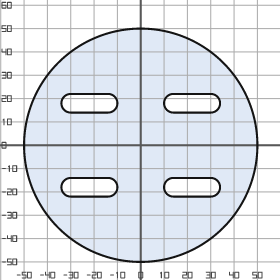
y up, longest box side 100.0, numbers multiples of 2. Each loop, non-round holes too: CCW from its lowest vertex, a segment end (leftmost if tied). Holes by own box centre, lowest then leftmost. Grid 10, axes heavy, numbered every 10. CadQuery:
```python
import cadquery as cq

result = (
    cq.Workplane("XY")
    .moveTo(0.0, 0.0)
    .circle(50.0)
    .moveTo(-30.0, -22.0)
    .lineTo(-14.0, -22.0)
    .threePointArc((-10.0, -18.0), (-14.0, -14.0))
    .lineTo(-30.0, -14.0)
    .threePointArc((-34.0, -18.0), (-30.0, -22.0))
    .close()
    .moveTo(14.0, -22.0)
    .lineTo(30.0, -22.0)
    .threePointArc((34.0, -18.0), (30.0, -14.0))
    .lineTo(14.0, -14.0)
    .threePointArc((10.0, -18.0), (14.0, -22.0))
    .close()
    .moveTo(-30.0, 14.0)
    .lineTo(-14.0, 14.0)
    .threePointArc((-10.0, 18.0), (-14.0, 22.0))
    .lineTo(-30.0, 22.0)
    .threePointArc((-34.0, 18.0), (-30.0, 14.0))
    .close()
    .moveTo(14.0, 14.0)
    .lineTo(30.0, 14.0)
    .threePointArc((34.0, 18.0), (30.0, 22.0))
    .lineTo(14.0, 22.0)
    .threePointArc((10.0, 18.0), (14.0, 14.0))
    .close()
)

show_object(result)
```